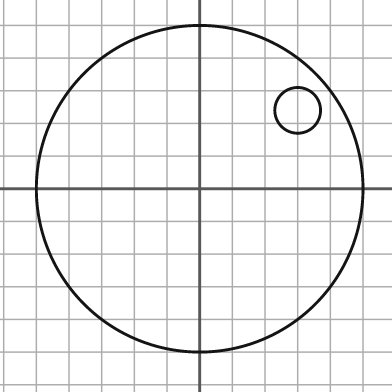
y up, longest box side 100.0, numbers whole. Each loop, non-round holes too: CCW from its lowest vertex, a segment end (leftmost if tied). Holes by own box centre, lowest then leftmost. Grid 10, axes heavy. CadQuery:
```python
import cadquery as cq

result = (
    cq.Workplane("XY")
    .moveTo(0.0, 0.0)
    .circle(50.0)
    .moveTo(30.0, 24.0)
    .circle(7.0)
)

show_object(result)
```